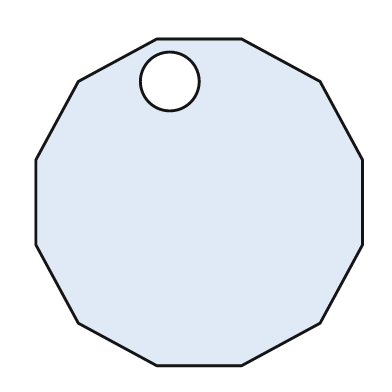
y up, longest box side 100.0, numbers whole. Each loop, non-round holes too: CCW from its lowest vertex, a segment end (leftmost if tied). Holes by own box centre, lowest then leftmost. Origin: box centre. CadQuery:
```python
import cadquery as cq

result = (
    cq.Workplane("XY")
    .moveTo(-13.0, -50.0)
    .lineTo(13.0, -50.0)
    .lineTo(37.0, -37.0)
    .lineTo(50.0, -13.0)
    .lineTo(50.0, 13.0)
    .lineTo(37.0, 37.0)
    .lineTo(13.0, 50.0)
    .lineTo(-13.0, 50.0)
    .lineTo(-37.0, 37.0)
    .lineTo(-50.0, 13.0)
    .lineTo(-50.0, -13.0)
    .lineTo(-37.0, -37.0)
    .close()
    .moveTo(-9.0, 37.0)
    .circle(9.0)
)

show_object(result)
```